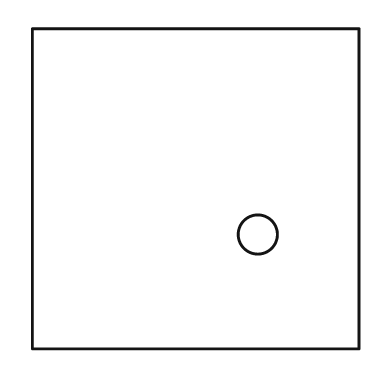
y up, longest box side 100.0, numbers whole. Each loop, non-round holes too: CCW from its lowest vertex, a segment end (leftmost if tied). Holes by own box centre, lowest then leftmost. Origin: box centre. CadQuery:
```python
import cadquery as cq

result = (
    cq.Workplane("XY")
    .moveTo(-50.0, -49.0)
    .lineTo(50.0, -49.0)
    .lineTo(50.0, 49.0)
    .lineTo(-50.0, 49.0)
    .close()
    .moveTo(19.0, -14.0)
    .circle(6.0)
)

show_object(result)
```